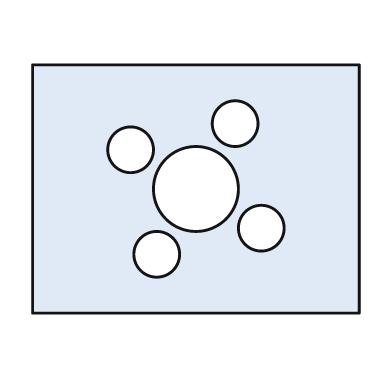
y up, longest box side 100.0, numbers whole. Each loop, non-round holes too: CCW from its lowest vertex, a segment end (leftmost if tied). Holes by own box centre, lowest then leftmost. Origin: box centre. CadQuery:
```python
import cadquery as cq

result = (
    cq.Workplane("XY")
    .moveTo(-50.0, -38.0)
    .lineTo(50.0, -38.0)
    .lineTo(50.0, 38.0)
    .lineTo(-50.0, 38.0)
    .close()
    .moveTo(-12.0, -20.0)
    .circle(7.0)
    .moveTo(20.0, -12.0)
    .circle(7.0)
    .moveTo(0.0, 0.0)
    .circle(13.0)
    .moveTo(-20.0, 12.0)
    .circle(7.0)
    .moveTo(12.0, 20.0)
    .circle(7.0)
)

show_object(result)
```